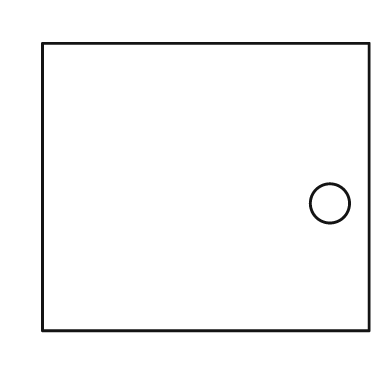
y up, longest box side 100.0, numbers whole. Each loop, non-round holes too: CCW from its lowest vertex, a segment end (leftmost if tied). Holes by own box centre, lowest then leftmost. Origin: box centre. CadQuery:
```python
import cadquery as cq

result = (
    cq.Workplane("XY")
    .moveTo(-50.0, -44.0)
    .lineTo(50.0, -44.0)
    .lineTo(50.0, 44.0)
    .lineTo(-50.0, 44.0)
    .close()
    .moveTo(38.0, -5.0)
    .circle(6.0)
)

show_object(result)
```